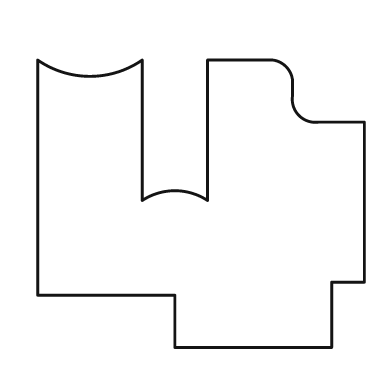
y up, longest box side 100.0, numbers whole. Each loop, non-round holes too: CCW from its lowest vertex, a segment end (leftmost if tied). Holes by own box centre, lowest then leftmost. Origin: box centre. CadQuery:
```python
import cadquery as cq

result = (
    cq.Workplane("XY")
    .moveTo(-8.0, -44.0)
    .lineTo(40.0, -44.0)
    .lineTo(40.0, -24.0)
    .lineTo(50.0, -24.0)
    .lineTo(50.0, 25.0)
    .lineTo(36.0, 25.0)
    .threePointArc((30.0, 27.0), (28.0, 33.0))
    .lineTo(28.0, 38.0)
    .threePointArc((26.0, 42.0), (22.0, 44.0))
    .lineTo(2.0, 44.0)
    .lineTo(2.0, 1.0)
    .threePointArc((-8.0, 4.0), (-18.0, 1.0))
    .lineTo(-18.0, 44.0)
    .threePointArc((-34.0, 39.0), (-50.0, 44.0))
    .lineTo(-50.0, -28.0)
    .lineTo(-8.0, -28.0)
    .close()
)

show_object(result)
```